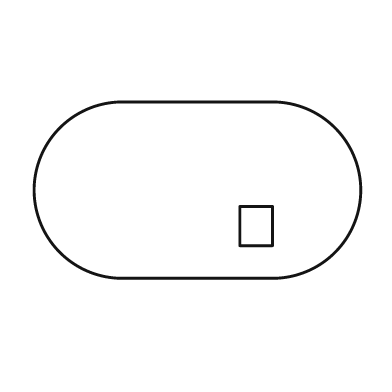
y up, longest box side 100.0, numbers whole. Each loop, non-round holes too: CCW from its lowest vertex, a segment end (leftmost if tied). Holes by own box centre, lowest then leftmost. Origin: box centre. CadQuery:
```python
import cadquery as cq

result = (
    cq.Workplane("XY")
    .moveTo(-23.0, -27.0)
    .lineTo(23.0, -27.0)
    .threePointArc((50.0, 0.0), (23.0, 27.0))
    .lineTo(-23.0, 27.0)
    .threePointArc((-50.0, 0.0), (-23.0, -27.0))
    .close()
    .moveTo(13.0, -17.0)
    .lineTo(23.0, -17.0)
    .lineTo(23.0, -5.0)
    .lineTo(13.0, -5.0)
    .close()
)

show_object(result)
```